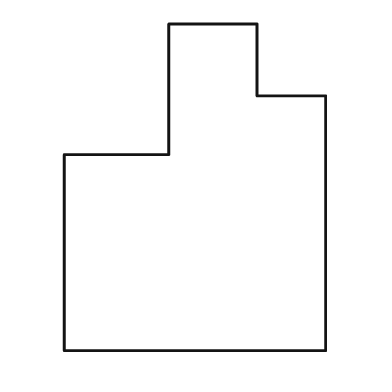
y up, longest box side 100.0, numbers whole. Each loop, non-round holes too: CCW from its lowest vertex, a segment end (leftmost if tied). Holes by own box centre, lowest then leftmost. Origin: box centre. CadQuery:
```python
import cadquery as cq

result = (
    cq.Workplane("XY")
    .moveTo(-40.0, -50.0)
    .lineTo(40.0, -50.0)
    .lineTo(40.0, 28.0)
    .lineTo(19.0, 28.0)
    .lineTo(19.0, 50.0)
    .lineTo(-8.0, 50.0)
    .lineTo(-8.0, 10.0)
    .lineTo(-40.0, 10.0)
    .close()
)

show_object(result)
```